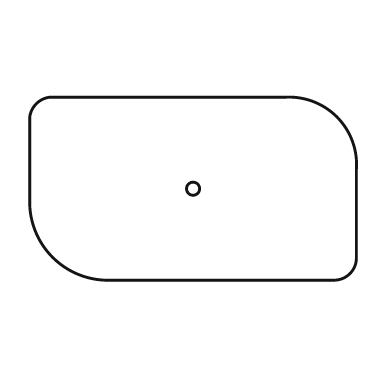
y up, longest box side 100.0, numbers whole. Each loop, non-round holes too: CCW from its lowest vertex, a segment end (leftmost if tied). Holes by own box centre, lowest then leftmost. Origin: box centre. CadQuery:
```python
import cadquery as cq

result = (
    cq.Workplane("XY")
    .moveTo(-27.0, -28.0)
    .lineTo(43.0, -28.0)
    .threePointArc((48.0, -26.0), (50.0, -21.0))
    .lineTo(50.0, 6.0)
    .threePointArc((44.0, 22.0), (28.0, 28.0))
    .lineTo(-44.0, 28.0)
    .threePointArc((-48.0, 26.0), (-50.0, 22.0))
    .lineTo(-50.0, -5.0)
    .threePointArc((-43.0, -21.0), (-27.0, -28.0))
    .close()
    .moveTo(0.0, 0.0)
    .circle(2.0)
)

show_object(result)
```